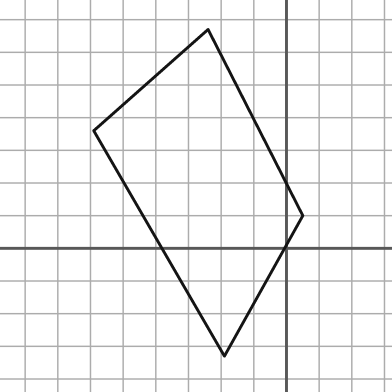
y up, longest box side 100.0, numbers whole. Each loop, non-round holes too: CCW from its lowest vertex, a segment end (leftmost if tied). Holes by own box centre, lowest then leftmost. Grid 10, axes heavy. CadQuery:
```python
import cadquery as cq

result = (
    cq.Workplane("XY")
    .moveTo(-19.0, -33.0)
    .lineTo(5.0, 10.0)
    .lineTo(-24.0, 67.0)
    .lineTo(-59.0, 36.0)
    .close()
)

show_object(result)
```